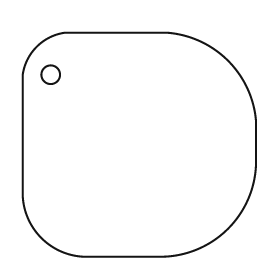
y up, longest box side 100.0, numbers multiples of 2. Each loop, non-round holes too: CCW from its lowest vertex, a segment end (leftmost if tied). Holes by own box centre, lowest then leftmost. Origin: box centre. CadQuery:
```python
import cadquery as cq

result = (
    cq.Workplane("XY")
    .moveTo(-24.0, -48.0)
    .lineTo(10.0, -48.0)
    .threePointArc((38.0, -36.0), (50.0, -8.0))
    .lineTo(50.0, 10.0)
    .threePointArc((38.0, 36.0), (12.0, 48.0))
    .lineTo(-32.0, 48.0)
    .threePointArc((-44.0, 42.0), (-50.0, 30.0))
    .lineTo(-50.0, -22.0)
    .threePointArc((-42.0, -40.0), (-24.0, -48.0))
    .close()
    .moveTo(-38.0, 30.0)
    .circle(4.0)
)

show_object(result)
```